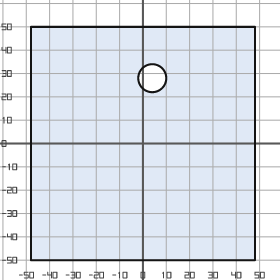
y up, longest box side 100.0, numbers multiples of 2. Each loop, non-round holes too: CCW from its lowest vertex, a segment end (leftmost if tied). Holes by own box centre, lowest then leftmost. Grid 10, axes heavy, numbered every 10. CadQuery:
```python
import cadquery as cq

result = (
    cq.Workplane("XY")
    .moveTo(-48.0, -50.0)
    .lineTo(48.0, -50.0)
    .lineTo(48.0, 50.0)
    .lineTo(-48.0, 50.0)
    .close()
    .moveTo(4.0, 28.0)
    .circle(6.0)
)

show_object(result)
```